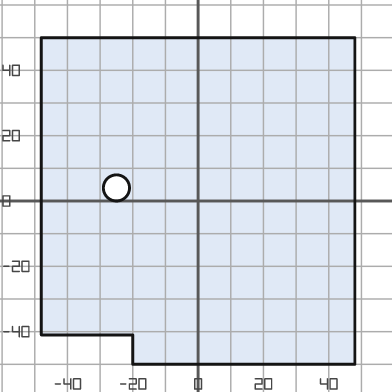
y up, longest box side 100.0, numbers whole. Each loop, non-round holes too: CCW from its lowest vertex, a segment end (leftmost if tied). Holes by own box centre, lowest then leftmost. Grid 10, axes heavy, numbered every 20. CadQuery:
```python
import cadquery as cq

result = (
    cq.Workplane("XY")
    .moveTo(-20.0, -50.0)
    .lineTo(48.0, -50.0)
    .lineTo(48.0, 50.0)
    .lineTo(-48.0, 50.0)
    .lineTo(-48.0, -41.0)
    .lineTo(-20.0, -41.0)
    .close()
    .moveTo(-25.0, 4.0)
    .circle(4.0)
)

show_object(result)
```